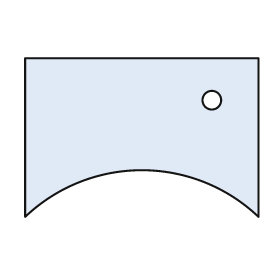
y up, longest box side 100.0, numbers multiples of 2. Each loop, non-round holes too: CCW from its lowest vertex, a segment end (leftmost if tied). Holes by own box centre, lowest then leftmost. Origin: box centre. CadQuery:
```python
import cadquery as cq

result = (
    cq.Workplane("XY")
    .moveTo(-50.0, -34.0)
    .threePointArc((0.0, -14.0), (50.0, -34.0))
    .lineTo(50.0, 34.0)
    .lineTo(-50.0, 34.0)
    .close()
    .moveTo(30.0, 16.0)
    .circle(4.0)
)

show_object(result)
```